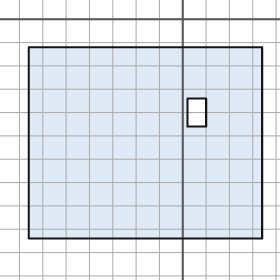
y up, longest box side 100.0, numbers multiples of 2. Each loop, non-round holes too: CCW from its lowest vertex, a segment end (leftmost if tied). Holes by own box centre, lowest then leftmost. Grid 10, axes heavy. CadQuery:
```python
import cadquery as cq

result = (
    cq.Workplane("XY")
    .moveTo(-66.0, -94.0)
    .lineTo(34.0, -94.0)
    .lineTo(34.0, -12.0)
    .lineTo(-66.0, -12.0)
    .close()
    .moveTo(2.0, -46.0)
    .lineTo(10.0, -46.0)
    .lineTo(10.0, -34.0)
    .lineTo(2.0, -34.0)
    .close()
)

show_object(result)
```